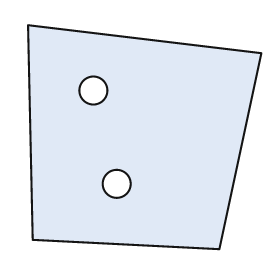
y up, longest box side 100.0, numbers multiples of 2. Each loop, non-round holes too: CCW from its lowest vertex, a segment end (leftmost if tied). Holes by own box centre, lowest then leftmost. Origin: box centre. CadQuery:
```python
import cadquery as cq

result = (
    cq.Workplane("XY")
    .moveTo(32.0, -48.0)
    .lineTo(50.0, 36.0)
    .lineTo(-50.0, 48.0)
    .lineTo(-48.0, -44.0)
    .close()
    .moveTo(-12.0, -20.0)
    .circle(6.0)
    .moveTo(-22.0, 20.0)
    .circle(6.0)
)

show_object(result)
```